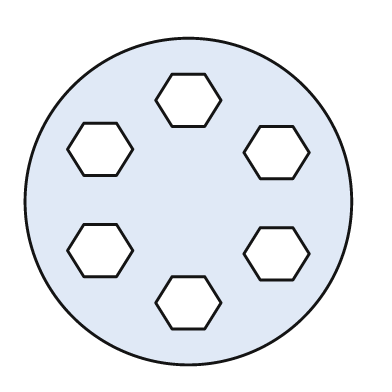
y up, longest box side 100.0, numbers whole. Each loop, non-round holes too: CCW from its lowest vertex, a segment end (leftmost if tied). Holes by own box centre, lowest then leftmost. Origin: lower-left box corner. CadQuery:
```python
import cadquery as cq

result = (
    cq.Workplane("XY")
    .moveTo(50.0, 50.0)
    .circle(50.0)
    .moveTo(45.0, 11.0)
    .lineTo(55.0, 11.0)
    .lineTo(60.0, 19.0)
    .lineTo(55.0, 27.0)
    .lineTo(45.0, 27.0)
    .lineTo(40.0, 19.0)
    .close()
    .moveTo(72.0, 26.0)
    .lineTo(82.0, 26.0)
    .lineTo(87.0, 34.0)
    .lineTo(82.0, 42.0)
    .lineTo(72.0, 42.0)
    .lineTo(67.0, 34.0)
    .close()
    .moveTo(18.0, 27.0)
    .lineTo(28.0, 27.0)
    .lineTo(33.0, 35.0)
    .lineTo(28.0, 43.0)
    .lineTo(18.0, 43.0)
    .lineTo(13.0, 35.0)
    .close()
    .moveTo(72.0, 57.0)
    .lineTo(82.0, 57.0)
    .lineTo(87.0, 65.0)
    .lineTo(82.0, 73.0)
    .lineTo(72.0, 73.0)
    .lineTo(67.0, 65.0)
    .close()
    .moveTo(18.0, 58.0)
    .lineTo(28.0, 58.0)
    .lineTo(33.0, 66.0)
    .lineTo(28.0, 74.0)
    .lineTo(18.0, 74.0)
    .lineTo(13.0, 66.0)
    .close()
    .moveTo(45.0, 73.0)
    .lineTo(55.0, 73.0)
    .lineTo(60.0, 81.0)
    .lineTo(55.0, 89.0)
    .lineTo(45.0, 89.0)
    .lineTo(40.0, 81.0)
    .close()
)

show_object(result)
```